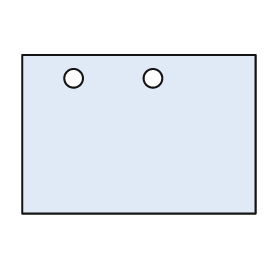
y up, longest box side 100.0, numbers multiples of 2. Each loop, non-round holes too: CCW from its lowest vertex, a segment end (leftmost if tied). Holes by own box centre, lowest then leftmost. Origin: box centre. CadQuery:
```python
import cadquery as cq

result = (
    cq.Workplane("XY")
    .moveTo(-50.0, -34.0)
    .lineTo(50.0, -34.0)
    .lineTo(50.0, 34.0)
    .lineTo(-50.0, 34.0)
    .close()
    .moveTo(-28.0, 24.0)
    .circle(4.0)
    .moveTo(6.0, 24.0)
    .circle(4.0)
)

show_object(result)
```